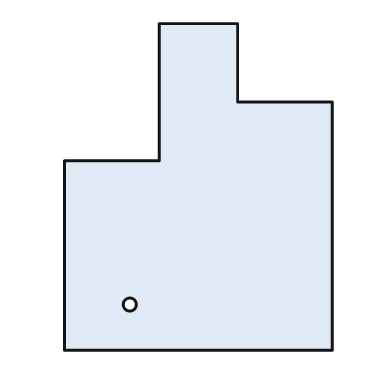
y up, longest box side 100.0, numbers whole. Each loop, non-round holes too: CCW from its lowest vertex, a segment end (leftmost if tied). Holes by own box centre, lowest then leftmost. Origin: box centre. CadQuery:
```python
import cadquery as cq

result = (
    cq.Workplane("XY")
    .moveTo(-41.0, -50.0)
    .lineTo(41.0, -50.0)
    .lineTo(41.0, 26.0)
    .lineTo(12.0, 26.0)
    .lineTo(12.0, 50.0)
    .lineTo(-12.0, 50.0)
    .lineTo(-12.0, 8.0)
    .lineTo(-41.0, 8.0)
    .close()
    .moveTo(-21.0, -36.0)
    .circle(2.0)
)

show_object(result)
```